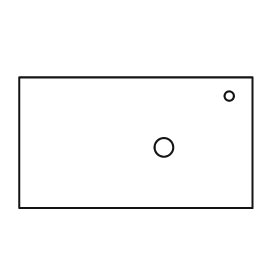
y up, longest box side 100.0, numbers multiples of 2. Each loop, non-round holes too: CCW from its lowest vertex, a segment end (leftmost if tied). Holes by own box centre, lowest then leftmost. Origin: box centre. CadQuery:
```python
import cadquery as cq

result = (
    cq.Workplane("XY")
    .moveTo(-50.0, -28.0)
    .lineTo(50.0, -28.0)
    .lineTo(50.0, 28.0)
    .lineTo(-50.0, 28.0)
    .close()
    .moveTo(12.0, -2.0)
    .circle(4.0)
    .moveTo(40.0, 20.0)
    .circle(2.0)
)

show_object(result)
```